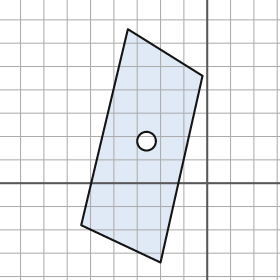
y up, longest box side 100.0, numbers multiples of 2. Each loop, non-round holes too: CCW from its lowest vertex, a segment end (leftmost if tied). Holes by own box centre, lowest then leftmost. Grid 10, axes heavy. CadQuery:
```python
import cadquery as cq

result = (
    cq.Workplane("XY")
    .moveTo(-20.0, -34.0)
    .lineTo(-2.0, 46.0)
    .lineTo(-34.0, 66.0)
    .lineTo(-54.0, -18.0)
    .close()
    .moveTo(-26.0, 18.0)
    .circle(4.0)
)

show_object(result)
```